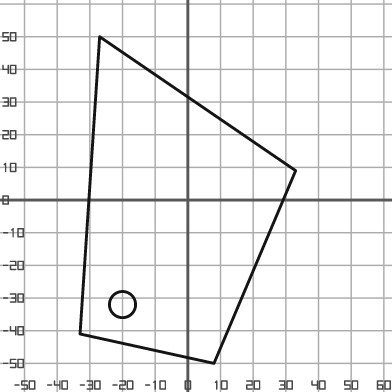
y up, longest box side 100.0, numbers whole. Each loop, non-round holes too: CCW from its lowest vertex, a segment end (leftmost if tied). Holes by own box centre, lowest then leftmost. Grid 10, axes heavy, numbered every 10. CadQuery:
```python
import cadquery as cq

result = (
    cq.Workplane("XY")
    .moveTo(8.0, -50.0)
    .lineTo(33.0, 9.0)
    .lineTo(-27.0, 50.0)
    .lineTo(-33.0, -41.0)
    .close()
    .moveTo(-20.0, -32.0)
    .circle(4.0)
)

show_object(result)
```